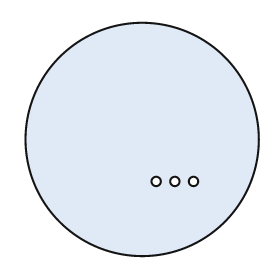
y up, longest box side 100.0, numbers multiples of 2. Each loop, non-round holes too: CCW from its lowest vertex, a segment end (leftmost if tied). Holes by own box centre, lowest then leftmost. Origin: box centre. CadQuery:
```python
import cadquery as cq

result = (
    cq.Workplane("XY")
    .moveTo(0.0, 0.0)
    .circle(50.0)
    .moveTo(6.0, -18.0)
    .circle(2.0)
    .moveTo(14.0, -18.0)
    .circle(2.0)
    .moveTo(22.0, -18.0)
    .circle(2.0)
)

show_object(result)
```